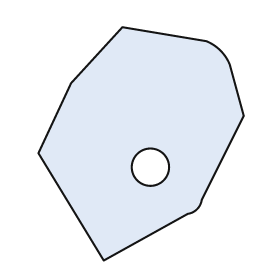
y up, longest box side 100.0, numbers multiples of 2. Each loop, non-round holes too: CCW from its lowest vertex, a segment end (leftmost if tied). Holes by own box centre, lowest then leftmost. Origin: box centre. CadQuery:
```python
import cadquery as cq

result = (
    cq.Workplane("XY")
    .moveTo(-16.0, -50.0)
    .lineTo(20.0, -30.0)
    .threePointArc((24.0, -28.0), (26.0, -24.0))
    .lineTo(44.0, 12.0)
    .lineTo(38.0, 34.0)
    .threePointArc((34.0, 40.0), (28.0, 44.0))
    .lineTo(-8.0, 50.0)
    .lineTo(-30.0, 26.0)
    .lineTo(-44.0, -4.0)
    .close()
    .moveTo(4.0, -10.0)
    .circle(8.0)
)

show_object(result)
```